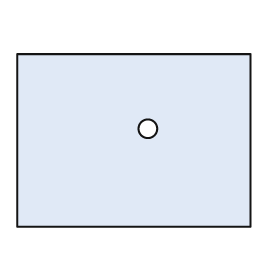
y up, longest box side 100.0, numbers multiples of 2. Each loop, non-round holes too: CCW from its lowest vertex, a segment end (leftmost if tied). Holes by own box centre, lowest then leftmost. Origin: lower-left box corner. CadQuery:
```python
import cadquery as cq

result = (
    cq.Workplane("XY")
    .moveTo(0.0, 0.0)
    .lineTo(100.0, 0.0)
    .lineTo(100.0, 74.0)
    .lineTo(0.0, 74.0)
    .close()
    .moveTo(56.0, 42.0)
    .circle(4.0)
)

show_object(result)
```